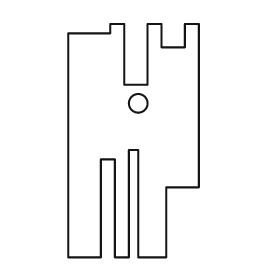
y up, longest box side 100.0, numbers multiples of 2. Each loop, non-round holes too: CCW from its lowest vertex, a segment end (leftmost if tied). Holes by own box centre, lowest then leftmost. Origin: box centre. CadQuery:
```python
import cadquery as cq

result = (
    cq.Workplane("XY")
    .moveTo(-28.0, -50.0)
    .lineTo(-14.0, -50.0)
    .lineTo(-14.0, -8.0)
    .lineTo(-8.0, -8.0)
    .lineTo(-8.0, -50.0)
    .lineTo(-2.0, -50.0)
    .lineTo(-2.0, -4.0)
    .lineTo(2.0, -4.0)
    .lineTo(2.0, -50.0)
    .lineTo(14.0, -50.0)
    .lineTo(14.0, -20.0)
    .lineTo(28.0, -20.0)
    .lineTo(28.0, 50.0)
    .lineTo(22.0, 50.0)
    .lineTo(22.0, 40.0)
    .lineTo(12.0, 40.0)
    .lineTo(12.0, 50.0)
    .lineTo(6.0, 50.0)
    .lineTo(6.0, 24.0)
    .lineTo(-4.0, 24.0)
    .lineTo(-4.0, 50.0)
    .lineTo(-10.0, 50.0)
    .lineTo(-10.0, 46.0)
    .lineTo(-28.0, 46.0)
    .close()
    .moveTo(2.0, 16.0)
    .circle(4.0)
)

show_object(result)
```